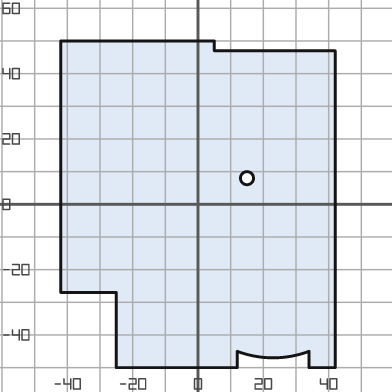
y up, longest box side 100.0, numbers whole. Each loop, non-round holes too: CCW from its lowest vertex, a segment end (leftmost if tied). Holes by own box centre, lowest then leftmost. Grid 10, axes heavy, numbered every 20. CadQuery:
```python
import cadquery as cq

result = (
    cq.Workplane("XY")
    .moveTo(-25.0, -50.0)
    .lineTo(12.0, -50.0)
    .lineTo(12.0, -45.0)
    .threePointArc((23.0, -47.0), (34.0, -45.0))
    .lineTo(34.0, -50.0)
    .lineTo(42.0, -50.0)
    .lineTo(42.0, 47.0)
    .lineTo(5.0, 47.0)
    .lineTo(5.0, 50.0)
    .lineTo(-42.0, 50.0)
    .lineTo(-42.0, -27.0)
    .lineTo(-25.0, -27.0)
    .close()
    .moveTo(15.0, 8.0)
    .circle(2.0)
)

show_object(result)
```